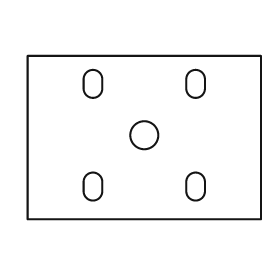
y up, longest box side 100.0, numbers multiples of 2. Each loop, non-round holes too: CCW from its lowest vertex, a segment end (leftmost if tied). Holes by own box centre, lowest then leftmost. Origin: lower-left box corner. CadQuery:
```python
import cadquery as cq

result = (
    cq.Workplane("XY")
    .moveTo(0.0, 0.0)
    .lineTo(100.0, 0.0)
    .lineTo(100.0, 70.0)
    .lineTo(0.0, 70.0)
    .close()
    .moveTo(24.0, 12.0)
    .threePointArc((28.0, 8.0), (32.0, 12.0))
    .lineTo(32.0, 16.0)
    .threePointArc((28.0, 20.0), (24.0, 16.0))
    .close()
    .moveTo(68.0, 12.0)
    .threePointArc((72.0, 8.0), (76.0, 12.0))
    .lineTo(76.0, 16.0)
    .threePointArc((72.0, 20.0), (68.0, 16.0))
    .close()
    .moveTo(50.0, 36.0)
    .circle(6.0)
    .moveTo(24.0, 56.0)
    .threePointArc((28.0, 52.0), (32.0, 56.0))
    .lineTo(32.0, 60.0)
    .threePointArc((28.0, 64.0), (24.0, 60.0))
    .close()
    .moveTo(68.0, 56.0)
    .threePointArc((72.0, 52.0), (76.0, 56.0))
    .lineTo(76.0, 60.0)
    .threePointArc((72.0, 64.0), (68.0, 60.0))
    .close()
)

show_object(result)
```